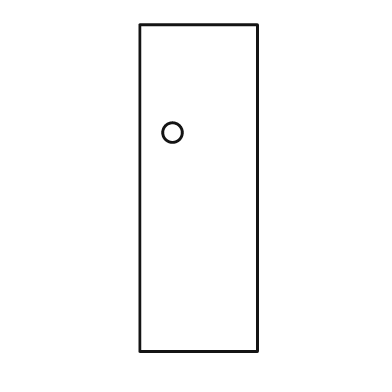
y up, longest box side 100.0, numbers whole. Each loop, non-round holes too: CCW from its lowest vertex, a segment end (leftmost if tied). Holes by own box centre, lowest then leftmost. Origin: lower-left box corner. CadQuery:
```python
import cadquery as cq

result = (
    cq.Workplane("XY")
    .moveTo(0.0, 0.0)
    .lineTo(36.0, 0.0)
    .lineTo(36.0, 100.0)
    .lineTo(0.0, 100.0)
    .close()
    .moveTo(10.0, 67.0)
    .circle(3.0)
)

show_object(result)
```